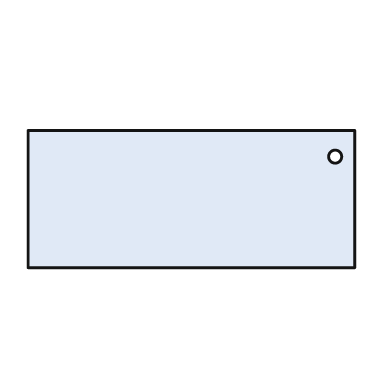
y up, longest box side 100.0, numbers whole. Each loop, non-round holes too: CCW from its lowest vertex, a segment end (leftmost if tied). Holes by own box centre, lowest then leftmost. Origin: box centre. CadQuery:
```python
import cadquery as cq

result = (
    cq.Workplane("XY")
    .moveTo(-50.0, -21.0)
    .lineTo(50.0, -21.0)
    .lineTo(50.0, 21.0)
    .lineTo(-50.0, 21.0)
    .close()
    .moveTo(44.0, 13.0)
    .circle(2.0)
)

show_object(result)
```